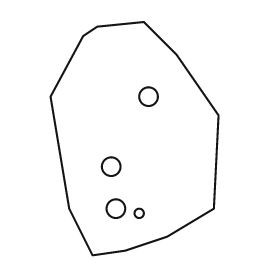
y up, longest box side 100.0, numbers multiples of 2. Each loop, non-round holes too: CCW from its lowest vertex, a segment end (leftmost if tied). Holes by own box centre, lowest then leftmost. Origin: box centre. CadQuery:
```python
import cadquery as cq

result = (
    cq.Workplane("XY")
    .moveTo(-18.0, -50.0)
    .lineTo(-4.0, -48.0)
    .lineTo(14.0, -42.0)
    .lineTo(34.0, -30.0)
    .lineTo(36.0, 10.0)
    .lineTo(18.0, 36.0)
    .lineTo(4.0, 50.0)
    .lineTo(-16.0, 48.0)
    .lineTo(-22.0, 44.0)
    .lineTo(-36.0, 18.0)
    .lineTo(-28.0, -30.0)
    .close()
    .moveTo(2.0, -32.0)
    .circle(2.0)
    .moveTo(-8.0, -30.0)
    .circle(4.0)
    .moveTo(-10.0, -12.0)
    .circle(4.0)
    .moveTo(6.0, 18.0)
    .circle(4.0)
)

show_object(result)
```